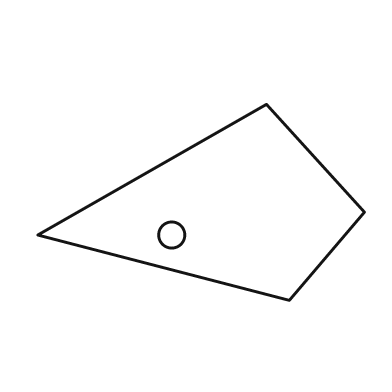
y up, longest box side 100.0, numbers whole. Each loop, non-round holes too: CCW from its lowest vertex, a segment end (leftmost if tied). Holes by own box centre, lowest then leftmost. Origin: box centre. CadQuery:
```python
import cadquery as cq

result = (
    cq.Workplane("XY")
    .moveTo(27.0, -30.0)
    .lineTo(50.0, -3.0)
    .lineTo(20.0, 30.0)
    .lineTo(-50.0, -10.0)
    .close()
    .moveTo(-9.0, -10.0)
    .circle(4.0)
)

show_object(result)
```